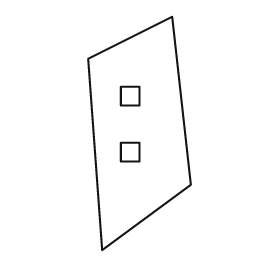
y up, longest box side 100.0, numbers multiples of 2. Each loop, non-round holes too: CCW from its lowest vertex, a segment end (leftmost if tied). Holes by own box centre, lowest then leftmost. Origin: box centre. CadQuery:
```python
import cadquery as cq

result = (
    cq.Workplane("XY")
    .moveTo(-16.0, -50.0)
    .lineTo(22.0, -22.0)
    .lineTo(14.0, 50.0)
    .lineTo(-22.0, 32.0)
    .close()
    .moveTo(-8.0, -12.0)
    .lineTo(0.0, -12.0)
    .lineTo(0.0, -4.0)
    .lineTo(-8.0, -4.0)
    .close()
    .moveTo(-8.0, 12.0)
    .lineTo(0.0, 12.0)
    .lineTo(0.0, 20.0)
    .lineTo(-8.0, 20.0)
    .close()
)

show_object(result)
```